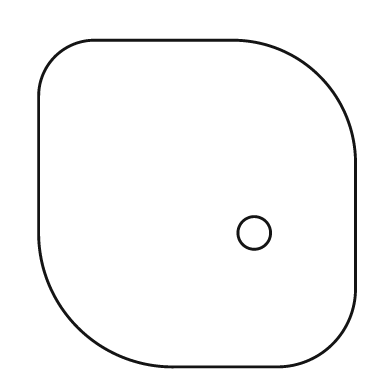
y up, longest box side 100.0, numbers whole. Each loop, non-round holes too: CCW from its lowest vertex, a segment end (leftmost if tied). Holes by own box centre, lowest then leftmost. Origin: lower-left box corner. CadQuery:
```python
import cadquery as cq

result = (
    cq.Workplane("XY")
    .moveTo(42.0, 0.0)
    .lineTo(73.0, 0.0)
    .threePointArc((90.0, 7.0), (97.0, 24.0))
    .lineTo(97.0, 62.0)
    .threePointArc((86.0, 89.0), (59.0, 100.0))
    .lineTo(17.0, 100.0)
    .threePointArc((5.0, 95.0), (0.0, 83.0))
    .lineTo(0.0, 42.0)
    .threePointArc((12.0, 12.0), (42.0, 0.0))
    .close()
    .moveTo(66.0, 41.0)
    .circle(5.0)
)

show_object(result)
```